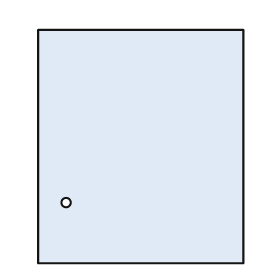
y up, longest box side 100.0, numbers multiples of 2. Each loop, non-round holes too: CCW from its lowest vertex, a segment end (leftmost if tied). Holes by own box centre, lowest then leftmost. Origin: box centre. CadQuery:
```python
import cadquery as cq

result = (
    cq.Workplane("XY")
    .moveTo(-44.0, -50.0)
    .lineTo(44.0, -50.0)
    .lineTo(44.0, 50.0)
    .lineTo(-44.0, 50.0)
    .close()
    .moveTo(-32.0, -24.0)
    .circle(2.0)
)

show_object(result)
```